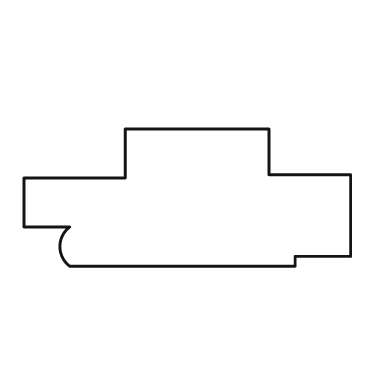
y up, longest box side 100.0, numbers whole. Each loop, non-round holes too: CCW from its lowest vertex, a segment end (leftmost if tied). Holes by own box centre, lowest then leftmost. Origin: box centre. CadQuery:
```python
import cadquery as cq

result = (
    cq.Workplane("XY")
    .moveTo(-36.0, -21.0)
    .lineTo(33.0, -21.0)
    .lineTo(33.0, -18.0)
    .lineTo(50.0, -18.0)
    .lineTo(50.0, 7.0)
    .lineTo(25.0, 7.0)
    .lineTo(25.0, 21.0)
    .lineTo(-19.0, 21.0)
    .lineTo(-19.0, 6.0)
    .lineTo(-50.0, 6.0)
    .lineTo(-50.0, -9.0)
    .lineTo(-36.0, -9.0)
    .threePointArc((-39.0, -15.0), (-36.0, -21.0))
    .close()
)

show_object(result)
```